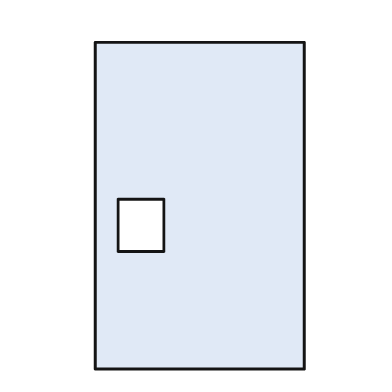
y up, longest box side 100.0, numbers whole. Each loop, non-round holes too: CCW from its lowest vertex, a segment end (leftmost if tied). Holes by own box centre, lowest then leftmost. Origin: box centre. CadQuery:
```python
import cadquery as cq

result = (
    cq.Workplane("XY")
    .moveTo(-32.0, -50.0)
    .lineTo(32.0, -50.0)
    .lineTo(32.0, 50.0)
    .lineTo(-32.0, 50.0)
    .close()
    .moveTo(-25.0, -14.0)
    .lineTo(-11.0, -14.0)
    .lineTo(-11.0, 2.0)
    .lineTo(-25.0, 2.0)
    .close()
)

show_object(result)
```